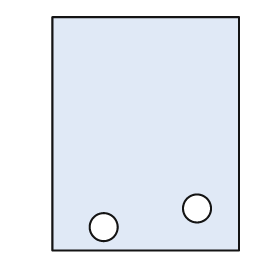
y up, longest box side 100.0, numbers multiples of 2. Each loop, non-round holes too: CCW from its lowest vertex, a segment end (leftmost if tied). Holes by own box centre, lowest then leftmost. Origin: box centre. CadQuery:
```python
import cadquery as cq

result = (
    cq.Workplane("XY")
    .moveTo(-40.0, -50.0)
    .lineTo(40.0, -50.0)
    .lineTo(40.0, 50.0)
    .lineTo(-40.0, 50.0)
    .close()
    .moveTo(-18.0, -40.0)
    .circle(6.0)
    .moveTo(22.0, -32.0)
    .circle(6.0)
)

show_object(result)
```